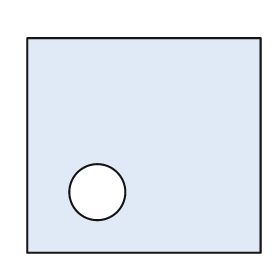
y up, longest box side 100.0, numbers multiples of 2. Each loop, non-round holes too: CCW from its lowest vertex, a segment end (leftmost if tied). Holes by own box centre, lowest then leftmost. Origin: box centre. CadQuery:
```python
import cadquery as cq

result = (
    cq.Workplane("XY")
    .moveTo(-50.0, -46.0)
    .lineTo(50.0, -46.0)
    .lineTo(50.0, 46.0)
    .lineTo(-50.0, 46.0)
    .close()
    .moveTo(-20.0, -20.0)
    .circle(12.0)
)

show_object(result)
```